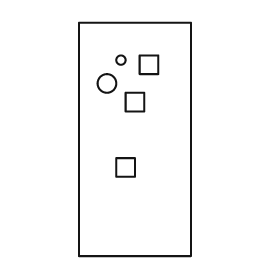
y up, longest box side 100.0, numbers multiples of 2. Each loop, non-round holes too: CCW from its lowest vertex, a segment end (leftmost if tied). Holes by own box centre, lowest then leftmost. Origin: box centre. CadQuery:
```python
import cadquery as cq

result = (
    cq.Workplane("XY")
    .moveTo(-24.0, -50.0)
    .lineTo(24.0, -50.0)
    .lineTo(24.0, 50.0)
    .lineTo(-24.0, 50.0)
    .close()
    .moveTo(-8.0, -16.0)
    .lineTo(0.0, -16.0)
    .lineTo(0.0, -8.0)
    .lineTo(-8.0, -8.0)
    .close()
    .moveTo(-4.0, 12.0)
    .lineTo(4.0, 12.0)
    .lineTo(4.0, 20.0)
    .lineTo(-4.0, 20.0)
    .close()
    .moveTo(-12.0, 24.0)
    .circle(4.0)
    .moveTo(2.0, 28.0)
    .lineTo(10.0, 28.0)
    .lineTo(10.0, 36.0)
    .lineTo(2.0, 36.0)
    .close()
    .moveTo(-6.0, 34.0)
    .circle(2.0)
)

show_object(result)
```